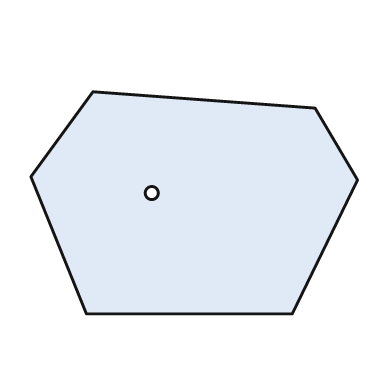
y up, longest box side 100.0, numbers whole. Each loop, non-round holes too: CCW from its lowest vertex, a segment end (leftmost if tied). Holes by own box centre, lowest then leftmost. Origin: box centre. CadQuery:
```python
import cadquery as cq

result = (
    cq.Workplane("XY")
    .moveTo(-33.0, -34.0)
    .lineTo(30.0, -34.0)
    .lineTo(50.0, 7.0)
    .lineTo(37.0, 29.0)
    .lineTo(-31.0, 34.0)
    .lineTo(-50.0, 8.0)
    .close()
    .moveTo(-13.0, 3.0)
    .circle(2.0)
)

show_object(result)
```